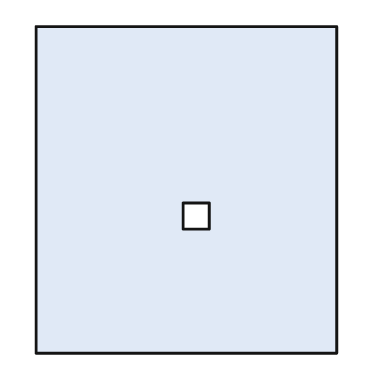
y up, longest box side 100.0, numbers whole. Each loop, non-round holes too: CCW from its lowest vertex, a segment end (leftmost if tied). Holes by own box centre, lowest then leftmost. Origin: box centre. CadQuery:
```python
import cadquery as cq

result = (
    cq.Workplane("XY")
    .moveTo(-46.0, -50.0)
    .lineTo(46.0, -50.0)
    .lineTo(46.0, 50.0)
    .lineTo(-46.0, 50.0)
    .close()
    .moveTo(-1.0, -12.0)
    .lineTo(7.0, -12.0)
    .lineTo(7.0, -4.0)
    .lineTo(-1.0, -4.0)
    .close()
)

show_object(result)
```